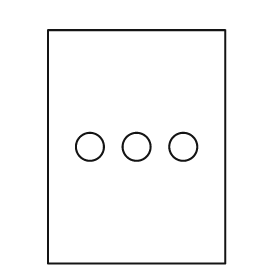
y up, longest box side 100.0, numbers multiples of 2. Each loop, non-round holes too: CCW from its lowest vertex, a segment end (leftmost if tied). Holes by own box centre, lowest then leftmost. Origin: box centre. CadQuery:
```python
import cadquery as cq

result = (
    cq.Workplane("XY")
    .moveTo(-38.0, -50.0)
    .lineTo(38.0, -50.0)
    .lineTo(38.0, 50.0)
    .lineTo(-38.0, 50.0)
    .close()
    .moveTo(-20.0, 0.0)
    .circle(6.0)
    .moveTo(0.0, 0.0)
    .circle(6.0)
    .moveTo(20.0, 0.0)
    .circle(6.0)
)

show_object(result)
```